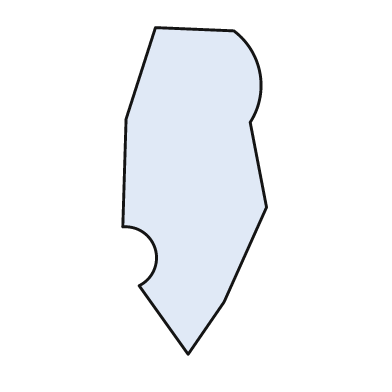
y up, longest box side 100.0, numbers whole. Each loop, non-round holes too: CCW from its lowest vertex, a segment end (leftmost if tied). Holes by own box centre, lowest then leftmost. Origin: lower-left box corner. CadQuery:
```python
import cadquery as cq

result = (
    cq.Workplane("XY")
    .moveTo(20.0, 0.0)
    .lineTo(31.0, 16.0)
    .lineTo(44.0, 45.0)
    .lineTo(39.0, 71.0)
    .threePointArc((42.0, 86.0), (34.0, 99.0))
    .lineTo(10.0, 100.0)
    .lineTo(1.0, 72.0)
    .lineTo(0.0, 39.0)
    .threePointArc((10.0, 32.0), (5.0, 21.0))
    .close()
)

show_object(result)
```